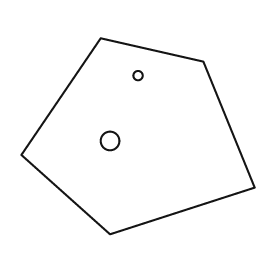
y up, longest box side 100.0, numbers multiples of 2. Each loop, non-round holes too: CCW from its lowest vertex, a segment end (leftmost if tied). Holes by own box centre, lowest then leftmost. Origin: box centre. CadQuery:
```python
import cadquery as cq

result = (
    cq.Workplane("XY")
    .moveTo(-12.0, -42.0)
    .lineTo(50.0, -22.0)
    .lineTo(28.0, 32.0)
    .lineTo(-16.0, 42.0)
    .lineTo(-50.0, -8.0)
    .close()
    .moveTo(-12.0, -2.0)
    .circle(4.0)
    .moveTo(0.0, 26.0)
    .circle(2.0)
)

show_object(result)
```